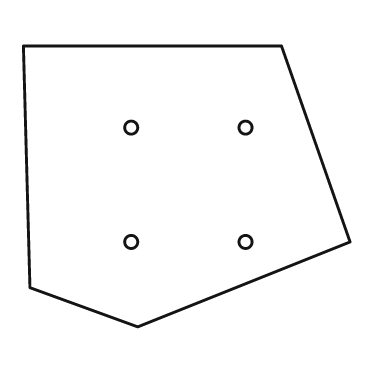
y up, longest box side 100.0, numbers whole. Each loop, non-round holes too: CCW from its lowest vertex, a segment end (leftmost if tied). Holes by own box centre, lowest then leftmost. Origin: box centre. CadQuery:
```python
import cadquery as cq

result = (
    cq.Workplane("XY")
    .moveTo(-15.0, -43.0)
    .lineTo(50.0, -17.0)
    .lineTo(29.0, 43.0)
    .lineTo(-50.0, 43.0)
    .lineTo(-48.0, -31.0)
    .close()
    .moveTo(-17.0, -17.0)
    .circle(2.0)
    .moveTo(18.0, -17.0)
    .circle(2.0)
    .moveTo(-17.0, 18.0)
    .circle(2.0)
    .moveTo(18.0, 18.0)
    .circle(2.0)
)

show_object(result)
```